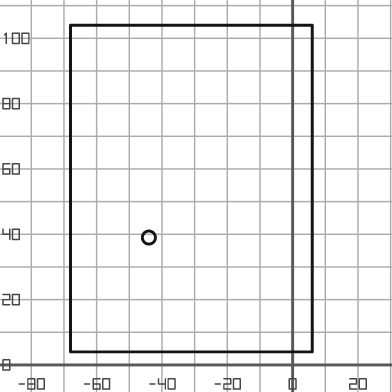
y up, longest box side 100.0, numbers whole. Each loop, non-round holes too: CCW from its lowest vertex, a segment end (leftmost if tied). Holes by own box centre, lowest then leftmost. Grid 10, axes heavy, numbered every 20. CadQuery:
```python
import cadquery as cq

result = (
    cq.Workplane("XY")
    .moveTo(-68.0, 4.0)
    .lineTo(6.0, 4.0)
    .lineTo(6.0, 104.0)
    .lineTo(-68.0, 104.0)
    .close()
    .moveTo(-44.0, 39.0)
    .circle(2.0)
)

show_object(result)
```